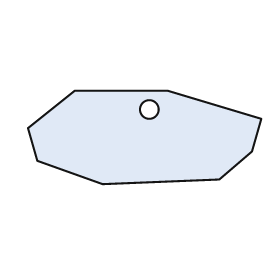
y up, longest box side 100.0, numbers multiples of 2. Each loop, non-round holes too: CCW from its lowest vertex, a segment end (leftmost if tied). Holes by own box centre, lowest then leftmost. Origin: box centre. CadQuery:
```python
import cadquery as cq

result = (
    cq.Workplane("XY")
    .moveTo(-18.0, -20.0)
    .lineTo(32.0, -18.0)
    .lineTo(46.0, -6.0)
    .lineTo(50.0, 8.0)
    .lineTo(10.0, 20.0)
    .lineTo(-30.0, 20.0)
    .lineTo(-50.0, 4.0)
    .lineTo(-46.0, -10.0)
    .close()
    .moveTo(2.0, 12.0)
    .circle(4.0)
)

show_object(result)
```